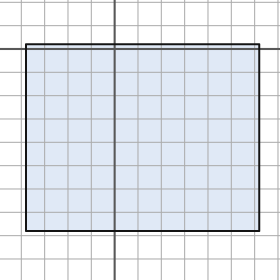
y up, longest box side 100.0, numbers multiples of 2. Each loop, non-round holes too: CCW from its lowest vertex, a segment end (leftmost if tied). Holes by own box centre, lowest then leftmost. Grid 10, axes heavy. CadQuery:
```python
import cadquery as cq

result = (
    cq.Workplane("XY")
    .moveTo(-38.0, -78.0)
    .lineTo(62.0, -78.0)
    .lineTo(62.0, 2.0)
    .lineTo(-38.0, 2.0)
    .close()
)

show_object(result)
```